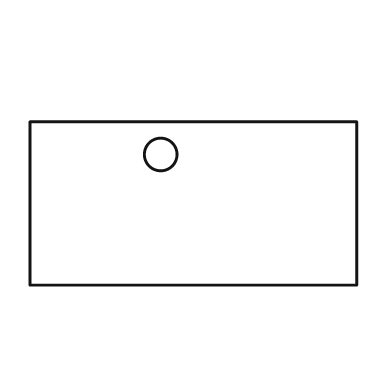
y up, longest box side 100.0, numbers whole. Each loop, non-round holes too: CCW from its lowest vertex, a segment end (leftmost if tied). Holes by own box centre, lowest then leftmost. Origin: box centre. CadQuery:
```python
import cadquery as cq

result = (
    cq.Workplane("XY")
    .moveTo(-50.0, -25.0)
    .lineTo(50.0, -25.0)
    .lineTo(50.0, 25.0)
    .lineTo(-50.0, 25.0)
    .close()
    .moveTo(-10.0, 15.0)
    .circle(5.0)
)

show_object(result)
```